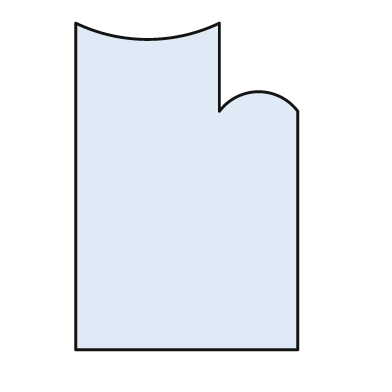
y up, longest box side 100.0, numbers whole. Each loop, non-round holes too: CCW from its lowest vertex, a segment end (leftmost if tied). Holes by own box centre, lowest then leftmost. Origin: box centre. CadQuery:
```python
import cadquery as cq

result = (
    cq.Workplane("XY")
    .moveTo(-34.0, -50.0)
    .lineTo(34.0, -50.0)
    .lineTo(34.0, 23.0)
    .threePointArc((22.0, 29.0), (10.0, 23.0))
    .lineTo(10.0, 50.0)
    .threePointArc((-12.0, 45.0), (-34.0, 50.0))
    .close()
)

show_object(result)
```